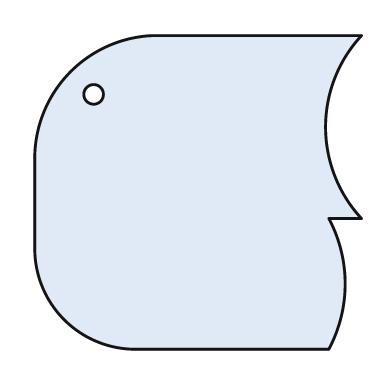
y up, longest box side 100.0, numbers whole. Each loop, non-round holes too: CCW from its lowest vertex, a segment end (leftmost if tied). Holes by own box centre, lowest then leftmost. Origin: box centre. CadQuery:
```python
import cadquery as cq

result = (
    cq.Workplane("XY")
    .moveTo(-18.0, -48.0)
    .lineTo(40.0, -48.0)
    .threePointArc((45.0, -28.0), (40.0, -8.0))
    .lineTo(50.0, -8.0)
    .threePointArc((39.0, 20.0), (50.0, 48.0))
    .lineTo(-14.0, 48.0)
    .threePointArc((-39.0, 37.0), (-50.0, 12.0))
    .lineTo(-50.0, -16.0)
    .threePointArc((-41.0, -39.0), (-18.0, -48.0))
    .close()
    .moveTo(-32.0, 30.0)
    .circle(3.0)
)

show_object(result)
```